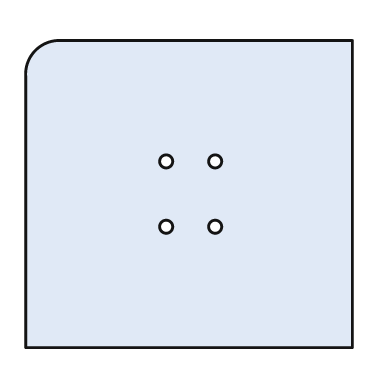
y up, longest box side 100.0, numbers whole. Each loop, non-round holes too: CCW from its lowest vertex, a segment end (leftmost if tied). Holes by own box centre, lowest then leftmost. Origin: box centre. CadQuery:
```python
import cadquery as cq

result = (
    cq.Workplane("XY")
    .moveTo(-50.0, -47.0)
    .lineTo(50.0, -47.0)
    .lineTo(50.0, 47.0)
    .lineTo(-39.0, 47.0)
    .threePointArc((-47.0, 44.0), (-50.0, 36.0))
    .close()
    .moveTo(-7.0, -10.0)
    .circle(2.0)
    .moveTo(8.0, -10.0)
    .circle(2.0)
    .moveTo(-7.0, 10.0)
    .circle(2.0)
    .moveTo(8.0, 10.0)
    .circle(2.0)
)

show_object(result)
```